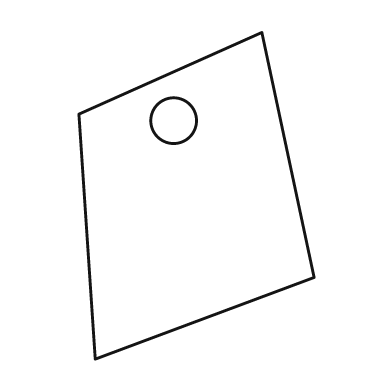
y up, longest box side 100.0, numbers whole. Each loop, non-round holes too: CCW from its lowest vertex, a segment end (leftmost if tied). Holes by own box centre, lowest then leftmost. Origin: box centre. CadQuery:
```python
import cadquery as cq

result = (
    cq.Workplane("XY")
    .moveTo(-31.0, -50.0)
    .lineTo(36.0, -25.0)
    .lineTo(20.0, 50.0)
    .lineTo(-36.0, 25.0)
    .close()
    .moveTo(-7.0, 23.0)
    .circle(7.0)
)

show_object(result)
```